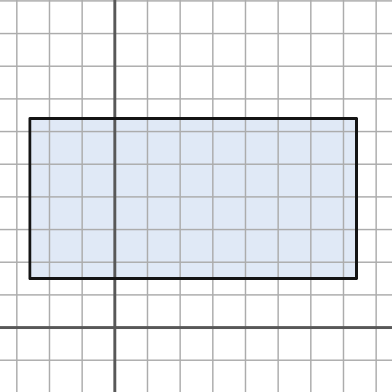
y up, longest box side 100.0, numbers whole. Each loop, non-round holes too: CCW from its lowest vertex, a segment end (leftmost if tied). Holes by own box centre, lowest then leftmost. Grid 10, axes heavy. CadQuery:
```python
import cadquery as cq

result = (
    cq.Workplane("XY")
    .moveTo(-26.0, 15.0)
    .lineTo(74.0, 15.0)
    .lineTo(74.0, 64.0)
    .lineTo(-26.0, 64.0)
    .close()
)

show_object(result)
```